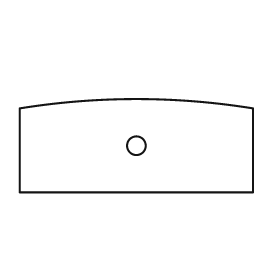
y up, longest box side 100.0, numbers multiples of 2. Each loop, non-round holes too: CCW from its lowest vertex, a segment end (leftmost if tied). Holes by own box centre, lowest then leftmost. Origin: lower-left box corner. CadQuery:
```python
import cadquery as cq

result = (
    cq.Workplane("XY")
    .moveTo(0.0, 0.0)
    .lineTo(100.0, 0.0)
    .lineTo(100.0, 36.0)
    .threePointArc((50.0, 40.0), (0.0, 36.0))
    .close()
    .moveTo(50.0, 20.0)
    .circle(4.0)
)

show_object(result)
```